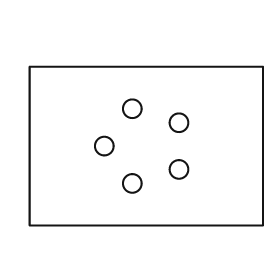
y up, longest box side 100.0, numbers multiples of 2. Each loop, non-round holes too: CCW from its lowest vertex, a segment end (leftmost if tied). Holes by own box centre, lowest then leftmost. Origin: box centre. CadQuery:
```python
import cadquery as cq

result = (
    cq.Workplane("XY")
    .moveTo(-50.0, -34.0)
    .lineTo(50.0, -34.0)
    .lineTo(50.0, 34.0)
    .lineTo(-50.0, 34.0)
    .close()
    .moveTo(-6.0, -16.0)
    .circle(4.0)
    .moveTo(14.0, -10.0)
    .circle(4.0)
    .moveTo(-18.0, 0.0)
    .circle(4.0)
    .moveTo(14.0, 10.0)
    .circle(4.0)
    .moveTo(-6.0, 16.0)
    .circle(4.0)
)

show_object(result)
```